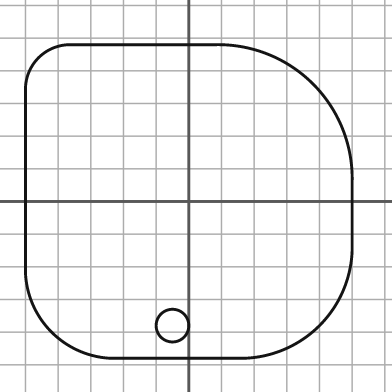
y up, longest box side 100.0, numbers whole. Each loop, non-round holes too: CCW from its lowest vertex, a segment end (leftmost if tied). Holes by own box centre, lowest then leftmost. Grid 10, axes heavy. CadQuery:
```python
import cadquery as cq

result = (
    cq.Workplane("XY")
    .moveTo(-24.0, -48.0)
    .lineTo(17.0, -48.0)
    .threePointArc((40.0, -38.0), (50.0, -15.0))
    .lineTo(50.0, 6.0)
    .threePointArc((38.0, 36.0), (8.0, 48.0))
    .lineTo(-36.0, 48.0)
    .threePointArc((-46.0, 44.0), (-50.0, 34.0))
    .lineTo(-50.0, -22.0)
    .threePointArc((-42.0, -40.0), (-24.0, -48.0))
    .close()
    .moveTo(-5.0, -38.0)
    .circle(5.0)
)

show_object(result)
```